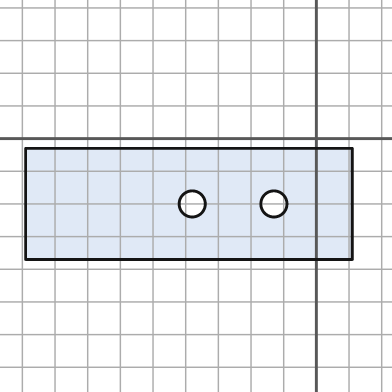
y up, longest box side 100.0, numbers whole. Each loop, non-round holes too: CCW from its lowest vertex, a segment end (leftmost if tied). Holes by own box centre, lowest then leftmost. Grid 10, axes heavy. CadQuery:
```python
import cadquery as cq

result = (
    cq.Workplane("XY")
    .moveTo(-89.0, -37.0)
    .lineTo(11.0, -37.0)
    .lineTo(11.0, -3.0)
    .lineTo(-89.0, -3.0)
    .close()
    .moveTo(-38.0, -20.0)
    .circle(4.0)
    .moveTo(-13.0, -20.0)
    .circle(4.0)
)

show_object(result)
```